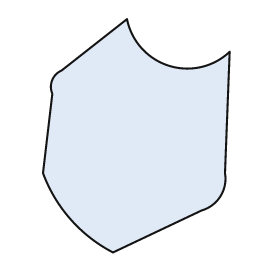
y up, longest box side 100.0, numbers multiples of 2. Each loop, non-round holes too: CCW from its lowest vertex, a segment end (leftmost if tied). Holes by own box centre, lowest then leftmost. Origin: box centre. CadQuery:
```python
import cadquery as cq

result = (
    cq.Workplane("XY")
    .moveTo(-10.0, -50.0)
    .lineTo(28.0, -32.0)
    .threePointArc((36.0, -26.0), (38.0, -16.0))
    .lineTo(40.0, 36.0)
    .threePointArc((14.0, 30.0), (-4.0, 50.0))
    .lineTo(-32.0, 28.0)
    .threePointArc((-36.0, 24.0), (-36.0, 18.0))
    .lineTo(-40.0, -16.0)
    .threePointArc((-28.0, -36.0), (-10.0, -50.0))
    .close()
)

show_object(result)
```